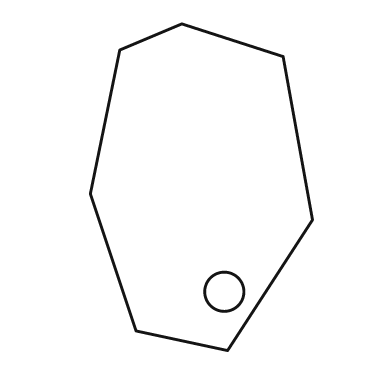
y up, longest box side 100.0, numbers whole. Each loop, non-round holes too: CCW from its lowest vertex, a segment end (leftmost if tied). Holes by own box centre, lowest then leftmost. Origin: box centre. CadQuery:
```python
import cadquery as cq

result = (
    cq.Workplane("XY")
    .moveTo(8.0, -50.0)
    .lineTo(34.0, -10.0)
    .lineTo(25.0, 40.0)
    .lineTo(-6.0, 50.0)
    .lineTo(-25.0, 42.0)
    .lineTo(-34.0, -2.0)
    .lineTo(-20.0, -44.0)
    .close()
    .moveTo(7.0, -32.0)
    .circle(6.0)
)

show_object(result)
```